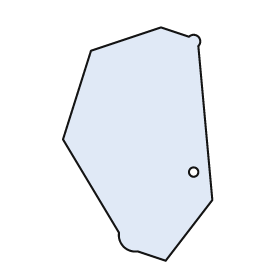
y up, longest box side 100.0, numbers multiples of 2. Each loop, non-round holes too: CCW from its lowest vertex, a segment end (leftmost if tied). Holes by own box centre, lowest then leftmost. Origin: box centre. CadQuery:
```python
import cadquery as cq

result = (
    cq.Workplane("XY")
    .moveTo(12.0, -50.0)
    .lineTo(32.0, -24.0)
    .lineTo(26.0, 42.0)
    .threePointArc((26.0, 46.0), (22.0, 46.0))
    .lineTo(10.0, 50.0)
    .lineTo(-20.0, 40.0)
    .lineTo(-32.0, 2.0)
    .lineTo(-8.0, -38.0)
    .threePointArc((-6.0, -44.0), (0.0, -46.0))
    .close()
    .moveTo(24.0, -12.0)
    .circle(2.0)
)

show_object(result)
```